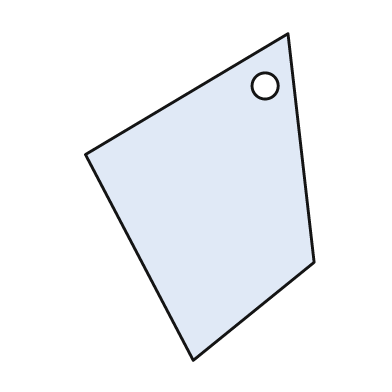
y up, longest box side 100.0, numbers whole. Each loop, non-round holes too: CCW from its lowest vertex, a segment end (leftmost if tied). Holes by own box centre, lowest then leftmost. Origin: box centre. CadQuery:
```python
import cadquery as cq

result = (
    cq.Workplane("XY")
    .moveTo(-2.0, -50.0)
    .lineTo(35.0, -20.0)
    .lineTo(27.0, 50.0)
    .lineTo(-35.0, 13.0)
    .close()
    .moveTo(20.0, 34.0)
    .circle(4.0)
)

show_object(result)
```